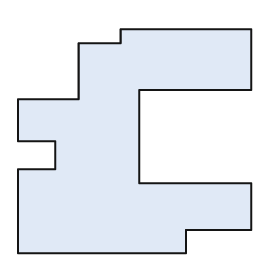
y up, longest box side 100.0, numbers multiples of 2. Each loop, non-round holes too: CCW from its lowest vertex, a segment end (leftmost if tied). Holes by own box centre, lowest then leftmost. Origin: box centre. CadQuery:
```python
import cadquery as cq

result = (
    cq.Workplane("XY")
    .moveTo(-50.0, -48.0)
    .lineTo(22.0, -48.0)
    .lineTo(22.0, -38.0)
    .lineTo(50.0, -38.0)
    .lineTo(50.0, -18.0)
    .lineTo(2.0, -18.0)
    .lineTo(2.0, 22.0)
    .lineTo(50.0, 22.0)
    .lineTo(50.0, 48.0)
    .lineTo(-6.0, 48.0)
    .lineTo(-6.0, 42.0)
    .lineTo(-24.0, 42.0)
    .lineTo(-24.0, 18.0)
    .lineTo(-50.0, 18.0)
    .lineTo(-50.0, 0.0)
    .lineTo(-34.0, 0.0)
    .lineTo(-34.0, -12.0)
    .lineTo(-50.0, -12.0)
    .close()
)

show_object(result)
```